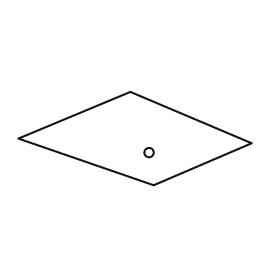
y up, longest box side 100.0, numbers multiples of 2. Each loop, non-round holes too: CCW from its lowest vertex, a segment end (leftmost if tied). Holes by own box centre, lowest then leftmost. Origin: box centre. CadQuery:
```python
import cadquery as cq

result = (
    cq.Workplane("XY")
    .moveTo(8.0, -20.0)
    .lineTo(50.0, -2.0)
    .lineTo(-2.0, 20.0)
    .lineTo(-50.0, 0.0)
    .close()
    .moveTo(6.0, -6.0)
    .circle(2.0)
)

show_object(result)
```